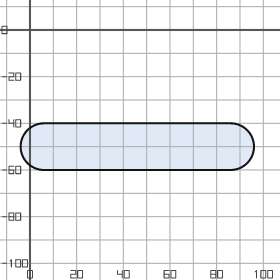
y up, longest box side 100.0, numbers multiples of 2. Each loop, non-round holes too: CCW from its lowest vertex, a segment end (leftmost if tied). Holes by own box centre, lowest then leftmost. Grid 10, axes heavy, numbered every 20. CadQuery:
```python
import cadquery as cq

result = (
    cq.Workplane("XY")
    .moveTo(6.0, -60.0)
    .lineTo(86.0, -60.0)
    .threePointArc((96.0, -50.0), (86.0, -40.0))
    .lineTo(6.0, -40.0)
    .threePointArc((-4.0, -50.0), (6.0, -60.0))
    .close()
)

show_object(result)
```